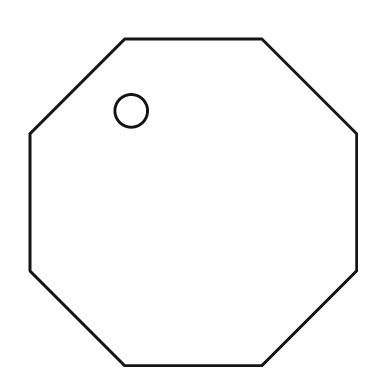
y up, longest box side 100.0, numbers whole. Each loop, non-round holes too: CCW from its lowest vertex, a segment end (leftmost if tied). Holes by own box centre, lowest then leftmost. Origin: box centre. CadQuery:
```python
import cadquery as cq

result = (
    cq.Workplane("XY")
    .moveTo(-21.0, -50.0)
    .lineTo(21.0, -50.0)
    .lineTo(50.0, -21.0)
    .lineTo(50.0, 21.0)
    .lineTo(21.0, 50.0)
    .lineTo(-21.0, 50.0)
    .lineTo(-50.0, 21.0)
    .lineTo(-50.0, -21.0)
    .close()
    .moveTo(-19.0, 28.0)
    .circle(5.0)
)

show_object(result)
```